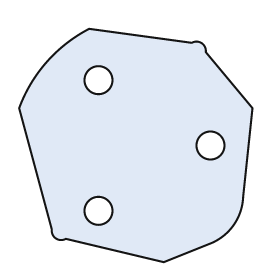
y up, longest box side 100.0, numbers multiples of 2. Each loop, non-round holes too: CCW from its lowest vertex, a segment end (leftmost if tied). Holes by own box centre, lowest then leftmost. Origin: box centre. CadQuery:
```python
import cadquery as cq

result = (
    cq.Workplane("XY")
    .moveTo(12.0, -50.0)
    .lineTo(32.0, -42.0)
    .threePointArc((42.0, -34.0), (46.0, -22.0))
    .lineTo(50.0, 16.0)
    .lineTo(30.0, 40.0)
    .threePointArc((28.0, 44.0), (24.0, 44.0))
    .lineTo(-20.0, 50.0)
    .threePointArc((-38.0, 36.0), (-50.0, 16.0))
    .lineTo(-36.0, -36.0)
    .threePointArc((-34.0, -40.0), (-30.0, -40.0))
    .close()
    .moveTo(-16.0, -28.0)
    .circle(6.0)
    .moveTo(32.0, 0.0)
    .circle(6.0)
    .moveTo(-16.0, 28.0)
    .circle(6.0)
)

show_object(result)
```